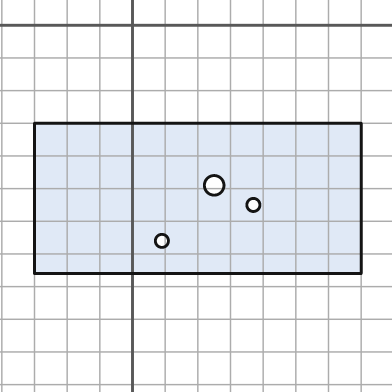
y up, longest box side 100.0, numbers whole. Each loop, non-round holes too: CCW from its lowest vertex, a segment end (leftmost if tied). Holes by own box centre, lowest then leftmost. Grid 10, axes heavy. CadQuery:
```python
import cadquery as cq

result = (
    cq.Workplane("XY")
    .moveTo(-30.0, -76.0)
    .lineTo(70.0, -76.0)
    .lineTo(70.0, -30.0)
    .lineTo(-30.0, -30.0)
    .close()
    .moveTo(9.0, -66.0)
    .circle(2.0)
    .moveTo(37.0, -55.0)
    .circle(2.0)
    .moveTo(25.0, -49.0)
    .circle(3.0)
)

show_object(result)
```